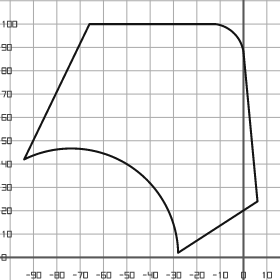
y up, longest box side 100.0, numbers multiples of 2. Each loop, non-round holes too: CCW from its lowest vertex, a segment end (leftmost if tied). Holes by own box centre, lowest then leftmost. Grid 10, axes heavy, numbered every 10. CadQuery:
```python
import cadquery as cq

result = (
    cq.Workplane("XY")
    .moveTo(-28.0, 2.0)
    .lineTo(6.0, 24.0)
    .lineTo(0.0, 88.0)
    .threePointArc((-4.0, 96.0), (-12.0, 100.0))
    .lineTo(-66.0, 100.0)
    .lineTo(-94.0, 42.0)
    .threePointArc((-50.0, 40.0), (-28.0, 2.0))
    .close()
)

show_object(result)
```